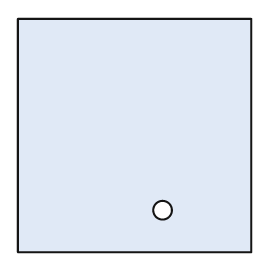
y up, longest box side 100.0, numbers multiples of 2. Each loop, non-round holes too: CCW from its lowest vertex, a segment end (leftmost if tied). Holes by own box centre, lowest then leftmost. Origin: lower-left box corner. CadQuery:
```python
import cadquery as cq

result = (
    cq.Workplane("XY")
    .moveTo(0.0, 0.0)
    .lineTo(100.0, 0.0)
    .lineTo(100.0, 100.0)
    .lineTo(0.0, 100.0)
    .close()
    .moveTo(62.0, 18.0)
    .circle(4.0)
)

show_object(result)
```